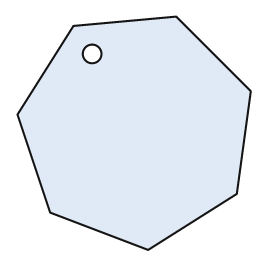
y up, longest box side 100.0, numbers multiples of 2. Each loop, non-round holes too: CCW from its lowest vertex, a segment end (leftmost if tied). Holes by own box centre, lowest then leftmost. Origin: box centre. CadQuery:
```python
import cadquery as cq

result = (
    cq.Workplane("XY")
    .moveTo(6.0, -50.0)
    .lineTo(44.0, -26.0)
    .lineTo(50.0, 18.0)
    .lineTo(18.0, 50.0)
    .lineTo(-26.0, 46.0)
    .lineTo(-50.0, 8.0)
    .lineTo(-36.0, -34.0)
    .close()
    .moveTo(-18.0, 34.0)
    .circle(4.0)
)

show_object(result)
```